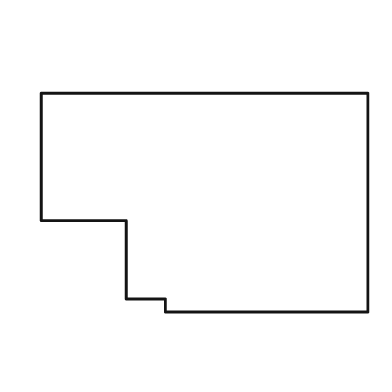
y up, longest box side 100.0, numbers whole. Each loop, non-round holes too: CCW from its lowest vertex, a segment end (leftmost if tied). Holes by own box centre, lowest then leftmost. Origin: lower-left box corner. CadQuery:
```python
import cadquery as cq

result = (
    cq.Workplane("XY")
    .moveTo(38.0, 0.0)
    .lineTo(100.0, 0.0)
    .lineTo(100.0, 67.0)
    .lineTo(0.0, 67.0)
    .lineTo(0.0, 28.0)
    .lineTo(26.0, 28.0)
    .lineTo(26.0, 4.0)
    .lineTo(38.0, 4.0)
    .close()
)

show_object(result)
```